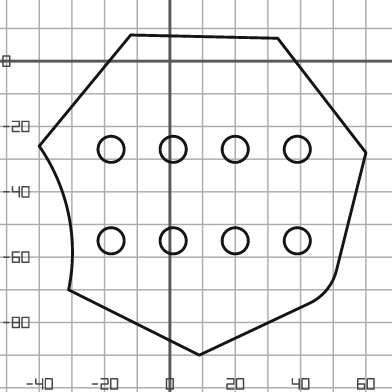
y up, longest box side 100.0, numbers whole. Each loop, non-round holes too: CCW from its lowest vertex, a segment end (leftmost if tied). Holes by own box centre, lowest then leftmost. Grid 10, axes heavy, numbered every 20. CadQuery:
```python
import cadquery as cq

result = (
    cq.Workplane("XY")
    .moveTo(9.0, -90.0)
    .lineTo(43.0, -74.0)
    .threePointArc((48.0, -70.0), (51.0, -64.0))
    .lineTo(60.0, -28.0)
    .lineTo(33.0, 7.0)
    .lineTo(-12.0, 8.0)
    .lineTo(-40.0, -26.0)
    .threePointArc((-31.0, -47.0), (-31.0, -70.0))
    .close()
    .moveTo(-18.0, -55.0)
    .circle(4.0)
    .moveTo(1.0, -55.0)
    .circle(4.0)
    .moveTo(20.0, -55.0)
    .circle(4.0)
    .moveTo(39.0, -55.0)
    .circle(4.0)
    .moveTo(-18.0, -27.0)
    .circle(4.0)
    .moveTo(1.0, -27.0)
    .circle(4.0)
    .moveTo(20.0, -27.0)
    .circle(4.0)
    .moveTo(39.0, -27.0)
    .circle(4.0)
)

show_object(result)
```